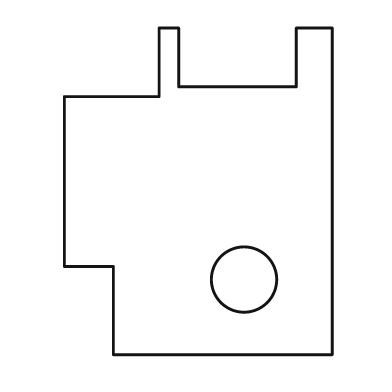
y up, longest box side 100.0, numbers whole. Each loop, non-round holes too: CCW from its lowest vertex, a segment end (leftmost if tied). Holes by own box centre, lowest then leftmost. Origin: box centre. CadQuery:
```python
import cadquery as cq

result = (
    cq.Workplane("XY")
    .moveTo(-26.0, -50.0)
    .lineTo(41.0, -50.0)
    .lineTo(41.0, 50.0)
    .lineTo(30.0, 50.0)
    .lineTo(30.0, 32.0)
    .lineTo(-6.0, 32.0)
    .lineTo(-6.0, 50.0)
    .lineTo(-12.0, 50.0)
    .lineTo(-12.0, 29.0)
    .lineTo(-41.0, 29.0)
    .lineTo(-41.0, -23.0)
    .lineTo(-26.0, -23.0)
    .close()
    .moveTo(14.0, -27.0)
    .circle(10.0)
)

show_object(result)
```